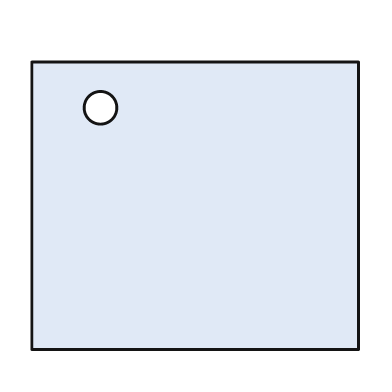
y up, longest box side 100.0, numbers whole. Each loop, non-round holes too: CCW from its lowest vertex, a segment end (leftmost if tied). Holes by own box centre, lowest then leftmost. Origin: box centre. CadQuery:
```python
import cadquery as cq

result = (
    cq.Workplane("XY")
    .moveTo(-50.0, -44.0)
    .lineTo(50.0, -44.0)
    .lineTo(50.0, 44.0)
    .lineTo(-50.0, 44.0)
    .close()
    .moveTo(-29.0, 30.0)
    .circle(5.0)
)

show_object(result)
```